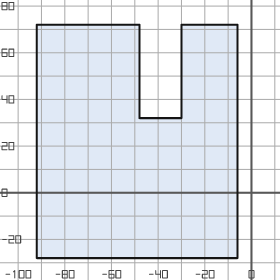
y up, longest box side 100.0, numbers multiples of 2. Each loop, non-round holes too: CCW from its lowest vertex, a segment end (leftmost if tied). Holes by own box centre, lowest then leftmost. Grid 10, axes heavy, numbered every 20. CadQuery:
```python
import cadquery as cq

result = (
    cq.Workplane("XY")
    .moveTo(-92.0, -28.0)
    .lineTo(-6.0, -28.0)
    .lineTo(-6.0, 72.0)
    .lineTo(-30.0, 72.0)
    .lineTo(-30.0, 32.0)
    .lineTo(-48.0, 32.0)
    .lineTo(-48.0, 72.0)
    .lineTo(-92.0, 72.0)
    .close()
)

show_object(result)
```